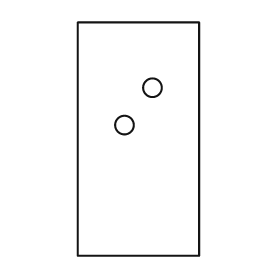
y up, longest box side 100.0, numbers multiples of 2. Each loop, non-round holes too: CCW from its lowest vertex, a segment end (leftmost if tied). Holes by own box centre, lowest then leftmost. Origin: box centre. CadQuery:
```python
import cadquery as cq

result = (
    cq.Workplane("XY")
    .moveTo(-26.0, -50.0)
    .lineTo(26.0, -50.0)
    .lineTo(26.0, 50.0)
    .lineTo(-26.0, 50.0)
    .close()
    .moveTo(-6.0, 6.0)
    .circle(4.0)
    .moveTo(6.0, 22.0)
    .circle(4.0)
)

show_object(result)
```